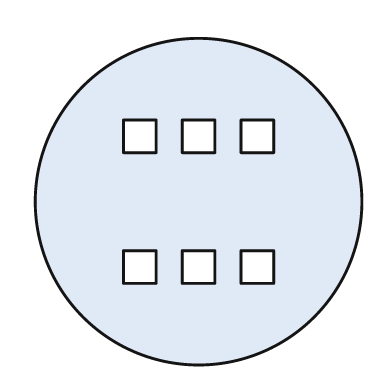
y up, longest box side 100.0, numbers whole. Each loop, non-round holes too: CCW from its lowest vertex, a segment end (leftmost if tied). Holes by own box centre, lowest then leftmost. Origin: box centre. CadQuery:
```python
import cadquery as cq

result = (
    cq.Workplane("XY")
    .moveTo(0.0, 0.0)
    .circle(50.0)
    .moveTo(-23.0, -25.0)
    .lineTo(-13.0, -25.0)
    .lineTo(-13.0, -15.0)
    .lineTo(-23.0, -15.0)
    .close()
    .moveTo(-5.0, -25.0)
    .lineTo(5.0, -25.0)
    .lineTo(5.0, -15.0)
    .lineTo(-5.0, -15.0)
    .close()
    .moveTo(13.0, -25.0)
    .lineTo(23.0, -25.0)
    .lineTo(23.0, -15.0)
    .lineTo(13.0, -15.0)
    .close()
    .moveTo(-23.0, 15.0)
    .lineTo(-13.0, 15.0)
    .lineTo(-13.0, 25.0)
    .lineTo(-23.0, 25.0)
    .close()
    .moveTo(-5.0, 15.0)
    .lineTo(5.0, 15.0)
    .lineTo(5.0, 25.0)
    .lineTo(-5.0, 25.0)
    .close()
    .moveTo(13.0, 15.0)
    .lineTo(23.0, 15.0)
    .lineTo(23.0, 25.0)
    .lineTo(13.0, 25.0)
    .close()
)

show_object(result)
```